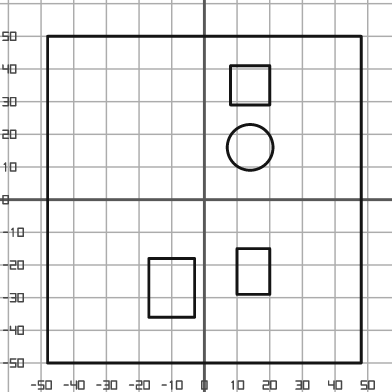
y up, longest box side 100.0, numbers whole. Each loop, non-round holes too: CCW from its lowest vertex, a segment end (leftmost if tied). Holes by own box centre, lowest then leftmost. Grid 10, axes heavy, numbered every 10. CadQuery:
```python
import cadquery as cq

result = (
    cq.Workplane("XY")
    .moveTo(-48.0, -50.0)
    .lineTo(48.0, -50.0)
    .lineTo(48.0, 50.0)
    .lineTo(-48.0, 50.0)
    .close()
    .moveTo(-17.0, -36.0)
    .lineTo(-3.0, -36.0)
    .lineTo(-3.0, -18.0)
    .lineTo(-17.0, -18.0)
    .close()
    .moveTo(10.0, -29.0)
    .lineTo(20.0, -29.0)
    .lineTo(20.0, -15.0)
    .lineTo(10.0, -15.0)
    .close()
    .moveTo(14.0, 16.0)
    .circle(7.0)
    .moveTo(8.0, 29.0)
    .lineTo(20.0, 29.0)
    .lineTo(20.0, 41.0)
    .lineTo(8.0, 41.0)
    .close()
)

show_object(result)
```